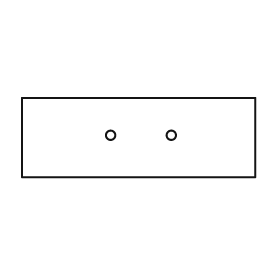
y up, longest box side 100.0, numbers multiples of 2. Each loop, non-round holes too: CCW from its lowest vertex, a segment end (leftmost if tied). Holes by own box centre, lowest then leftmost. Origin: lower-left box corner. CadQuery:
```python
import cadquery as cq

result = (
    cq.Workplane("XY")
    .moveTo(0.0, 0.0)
    .lineTo(100.0, 0.0)
    .lineTo(100.0, 34.0)
    .lineTo(0.0, 34.0)
    .close()
    .moveTo(38.0, 18.0)
    .circle(2.0)
    .moveTo(64.0, 18.0)
    .circle(2.0)
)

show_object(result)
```